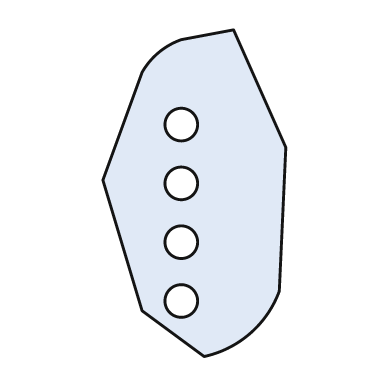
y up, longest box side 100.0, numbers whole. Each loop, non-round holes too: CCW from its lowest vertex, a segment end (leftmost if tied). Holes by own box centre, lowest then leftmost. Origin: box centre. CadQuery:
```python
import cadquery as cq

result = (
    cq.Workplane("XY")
    .moveTo(3.0, -50.0)
    .threePointArc((17.0, -43.0), (26.0, -30.0))
    .lineTo(28.0, 14.0)
    .lineTo(12.0, 50.0)
    .lineTo(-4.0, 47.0)
    .threePointArc((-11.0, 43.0), (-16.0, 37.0))
    .lineTo(-28.0, 4.0)
    .lineTo(-16.0, -36.0)
    .close()
    .moveTo(-4.0, -33.0)
    .circle(5.0)
    .moveTo(-4.0, -15.0)
    .circle(5.0)
    .moveTo(-4.0, 3.0)
    .circle(5.0)
    .moveTo(-4.0, 21.0)
    .circle(5.0)
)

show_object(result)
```